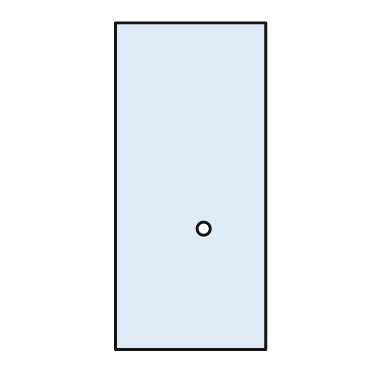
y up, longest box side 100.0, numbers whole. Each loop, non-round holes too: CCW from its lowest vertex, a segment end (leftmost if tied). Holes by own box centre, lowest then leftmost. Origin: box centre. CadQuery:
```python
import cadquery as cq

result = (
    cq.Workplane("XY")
    .moveTo(-23.0, -50.0)
    .lineTo(23.0, -50.0)
    .lineTo(23.0, 50.0)
    .lineTo(-23.0, 50.0)
    .close()
    .moveTo(4.0, -13.0)
    .circle(2.0)
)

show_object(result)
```